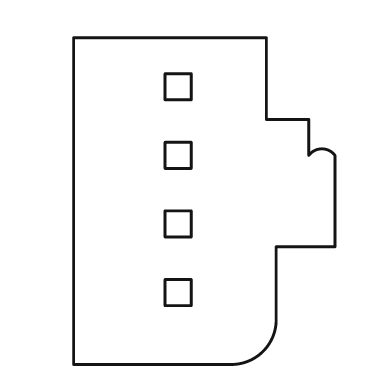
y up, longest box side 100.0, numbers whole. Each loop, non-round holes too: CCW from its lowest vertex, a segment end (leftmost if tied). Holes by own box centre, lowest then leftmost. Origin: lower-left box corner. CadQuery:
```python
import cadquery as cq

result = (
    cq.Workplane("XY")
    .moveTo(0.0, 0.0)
    .lineTo(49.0, 0.0)
    .threePointArc((58.0, 4.0), (62.0, 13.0))
    .lineTo(62.0, 36.0)
    .lineTo(80.0, 36.0)
    .lineTo(80.0, 64.0)
    .threePointArc((76.0, 66.0), (72.0, 64.0))
    .lineTo(72.0, 75.0)
    .lineTo(59.0, 75.0)
    .lineTo(59.0, 100.0)
    .lineTo(0.0, 100.0)
    .close()
    .moveTo(28.0, 18.0)
    .lineTo(36.0, 18.0)
    .lineTo(36.0, 26.0)
    .lineTo(28.0, 26.0)
    .close()
    .moveTo(28.0, 39.0)
    .lineTo(36.0, 39.0)
    .lineTo(36.0, 47.0)
    .lineTo(28.0, 47.0)
    .close()
    .moveTo(28.0, 60.0)
    .lineTo(36.0, 60.0)
    .lineTo(36.0, 68.0)
    .lineTo(28.0, 68.0)
    .close()
    .moveTo(28.0, 81.0)
    .lineTo(36.0, 81.0)
    .lineTo(36.0, 89.0)
    .lineTo(28.0, 89.0)
    .close()
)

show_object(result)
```